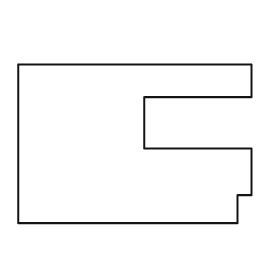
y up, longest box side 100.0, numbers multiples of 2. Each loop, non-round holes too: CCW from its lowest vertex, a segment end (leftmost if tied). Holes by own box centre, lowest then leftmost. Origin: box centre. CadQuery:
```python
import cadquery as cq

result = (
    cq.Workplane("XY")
    .moveTo(-50.0, -34.0)
    .lineTo(44.0, -34.0)
    .lineTo(44.0, -22.0)
    .lineTo(50.0, -22.0)
    .lineTo(50.0, -2.0)
    .lineTo(4.0, -2.0)
    .lineTo(4.0, 20.0)
    .lineTo(50.0, 20.0)
    .lineTo(50.0, 34.0)
    .lineTo(-50.0, 34.0)
    .close()
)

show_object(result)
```